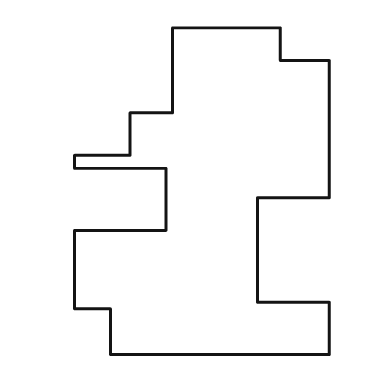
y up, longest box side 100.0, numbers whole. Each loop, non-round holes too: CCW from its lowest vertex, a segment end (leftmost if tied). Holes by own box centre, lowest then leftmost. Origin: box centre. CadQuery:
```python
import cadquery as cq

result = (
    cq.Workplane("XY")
    .moveTo(-28.0, -50.0)
    .lineTo(39.0, -50.0)
    .lineTo(39.0, -34.0)
    .lineTo(17.0, -34.0)
    .lineTo(17.0, -2.0)
    .lineTo(39.0, -2.0)
    .lineTo(39.0, 40.0)
    .lineTo(24.0, 40.0)
    .lineTo(24.0, 50.0)
    .lineTo(-9.0, 50.0)
    .lineTo(-9.0, 24.0)
    .lineTo(-22.0, 24.0)
    .lineTo(-22.0, 11.0)
    .lineTo(-39.0, 11.0)
    .lineTo(-39.0, 7.0)
    .lineTo(-11.0, 7.0)
    .lineTo(-11.0, -12.0)
    .lineTo(-39.0, -12.0)
    .lineTo(-39.0, -36.0)
    .lineTo(-28.0, -36.0)
    .close()
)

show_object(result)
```